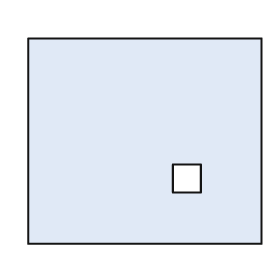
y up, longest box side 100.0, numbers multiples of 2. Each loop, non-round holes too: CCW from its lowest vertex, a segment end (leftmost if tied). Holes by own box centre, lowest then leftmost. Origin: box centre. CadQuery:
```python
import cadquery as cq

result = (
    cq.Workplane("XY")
    .moveTo(-50.0, -44.0)
    .lineTo(50.0, -44.0)
    .lineTo(50.0, 44.0)
    .lineTo(-50.0, 44.0)
    .close()
    .moveTo(12.0, -22.0)
    .lineTo(24.0, -22.0)
    .lineTo(24.0, -10.0)
    .lineTo(12.0, -10.0)
    .close()
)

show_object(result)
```